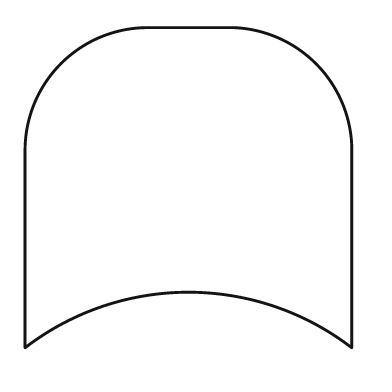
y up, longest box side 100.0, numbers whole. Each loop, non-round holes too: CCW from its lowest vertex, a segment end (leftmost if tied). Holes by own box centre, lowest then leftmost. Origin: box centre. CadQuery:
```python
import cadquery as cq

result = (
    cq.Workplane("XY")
    .moveTo(-50.0, -49.0)
    .threePointArc((0.0, -32.0), (50.0, -49.0))
    .lineTo(50.0, 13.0)
    .threePointArc((39.0, 38.0), (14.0, 49.0))
    .lineTo(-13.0, 49.0)
    .threePointArc((-39.0, 38.0), (-50.0, 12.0))
    .close()
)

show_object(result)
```